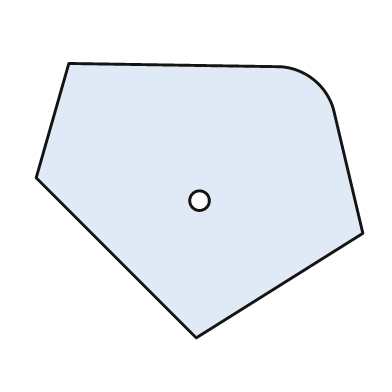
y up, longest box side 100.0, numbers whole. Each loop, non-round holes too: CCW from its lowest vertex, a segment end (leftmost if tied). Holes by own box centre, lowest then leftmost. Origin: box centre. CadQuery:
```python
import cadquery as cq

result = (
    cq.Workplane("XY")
    .moveTo(-1.0, -42.0)
    .lineTo(50.0, -10.0)
    .lineTo(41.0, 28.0)
    .threePointArc((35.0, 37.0), (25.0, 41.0))
    .lineTo(-40.0, 42.0)
    .lineTo(-50.0, 7.0)
    .close()
    .moveTo(0.0, 0.0)
    .circle(3.0)
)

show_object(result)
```